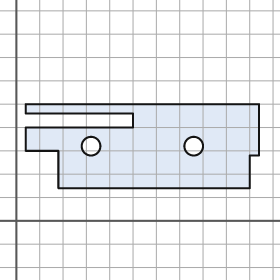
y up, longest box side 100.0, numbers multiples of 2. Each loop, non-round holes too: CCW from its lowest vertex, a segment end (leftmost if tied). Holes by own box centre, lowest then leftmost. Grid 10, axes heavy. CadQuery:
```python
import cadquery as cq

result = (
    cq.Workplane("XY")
    .moveTo(18.0, 14.0)
    .lineTo(100.0, 14.0)
    .lineTo(100.0, 28.0)
    .lineTo(104.0, 28.0)
    .lineTo(104.0, 50.0)
    .lineTo(4.0, 50.0)
    .lineTo(4.0, 46.0)
    .lineTo(50.0, 46.0)
    .lineTo(50.0, 40.0)
    .lineTo(4.0, 40.0)
    .lineTo(4.0, 30.0)
    .lineTo(18.0, 30.0)
    .close()
    .moveTo(32.0, 32.0)
    .circle(4.0)
    .moveTo(76.0, 32.0)
    .circle(4.0)
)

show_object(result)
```